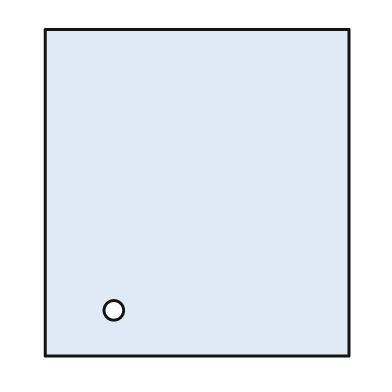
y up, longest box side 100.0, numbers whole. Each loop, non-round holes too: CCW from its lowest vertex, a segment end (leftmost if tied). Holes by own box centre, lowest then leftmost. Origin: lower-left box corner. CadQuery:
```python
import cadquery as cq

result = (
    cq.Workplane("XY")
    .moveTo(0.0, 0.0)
    .lineTo(93.0, 0.0)
    .lineTo(93.0, 100.0)
    .lineTo(0.0, 100.0)
    .close()
    .moveTo(21.0, 14.0)
    .circle(3.0)
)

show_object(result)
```